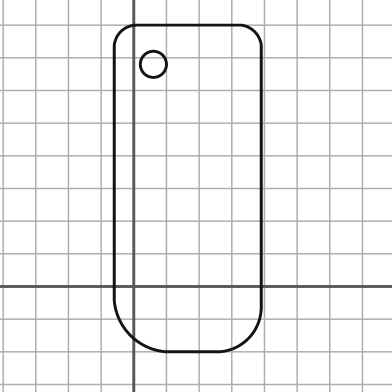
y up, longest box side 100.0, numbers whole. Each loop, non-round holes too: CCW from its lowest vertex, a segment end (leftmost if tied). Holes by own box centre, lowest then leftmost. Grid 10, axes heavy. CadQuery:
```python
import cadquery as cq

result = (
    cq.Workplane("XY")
    .moveTo(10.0, -20.0)
    .lineTo(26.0, -20.0)
    .threePointArc((35.0, -16.0), (39.0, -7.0))
    .lineTo(39.0, 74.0)
    .threePointArc((37.0, 78.0), (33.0, 80.0))
    .lineTo(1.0, 80.0)
    .threePointArc((-4.0, 78.0), (-6.0, 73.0))
    .lineTo(-6.0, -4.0)
    .threePointArc((-1.0, -15.0), (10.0, -20.0))
    .close()
    .moveTo(6.0, 68.0)
    .circle(4.0)
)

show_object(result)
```